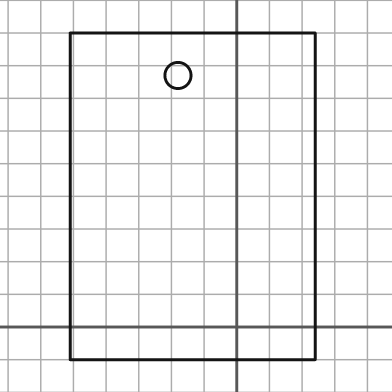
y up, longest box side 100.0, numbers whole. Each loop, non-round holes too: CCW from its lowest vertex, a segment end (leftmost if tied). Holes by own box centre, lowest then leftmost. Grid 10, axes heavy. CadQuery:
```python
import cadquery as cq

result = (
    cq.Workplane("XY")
    .moveTo(-51.0, -10.0)
    .lineTo(24.0, -10.0)
    .lineTo(24.0, 90.0)
    .lineTo(-51.0, 90.0)
    .close()
    .moveTo(-18.0, 77.0)
    .circle(4.0)
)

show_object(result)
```